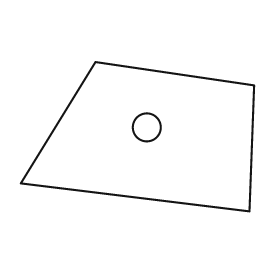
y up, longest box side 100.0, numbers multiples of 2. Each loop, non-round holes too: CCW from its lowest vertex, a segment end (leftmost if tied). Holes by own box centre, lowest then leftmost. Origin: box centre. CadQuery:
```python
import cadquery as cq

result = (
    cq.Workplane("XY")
    .moveTo(48.0, -32.0)
    .lineTo(50.0, 22.0)
    .lineTo(-18.0, 32.0)
    .lineTo(-50.0, -20.0)
    .close()
    .moveTo(4.0, 4.0)
    .circle(6.0)
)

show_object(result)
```